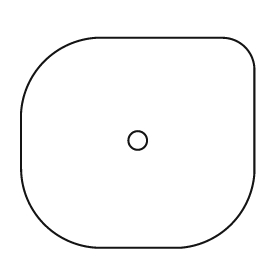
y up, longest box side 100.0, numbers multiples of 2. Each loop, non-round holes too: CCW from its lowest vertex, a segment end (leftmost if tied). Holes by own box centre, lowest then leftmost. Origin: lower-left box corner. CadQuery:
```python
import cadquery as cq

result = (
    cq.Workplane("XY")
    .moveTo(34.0, 0.0)
    .lineTo(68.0, 0.0)
    .threePointArc((90.0, 10.0), (100.0, 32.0))
    .lineTo(100.0, 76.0)
    .threePointArc((96.0, 86.0), (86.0, 90.0))
    .lineTo(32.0, 90.0)
    .threePointArc((10.0, 80.0), (0.0, 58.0))
    .lineTo(0.0, 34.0)
    .threePointArc((10.0, 10.0), (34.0, 0.0))
    .close()
    .moveTo(50.0, 46.0)
    .circle(4.0)
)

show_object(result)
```